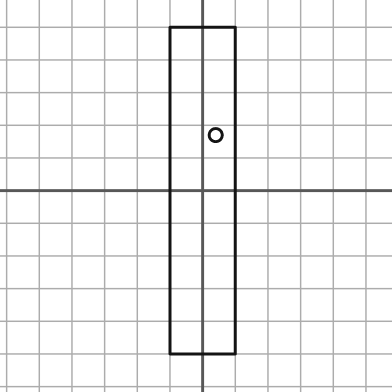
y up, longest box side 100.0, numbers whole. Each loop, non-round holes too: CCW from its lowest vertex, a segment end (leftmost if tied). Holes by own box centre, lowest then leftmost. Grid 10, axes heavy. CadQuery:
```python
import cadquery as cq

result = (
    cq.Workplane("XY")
    .moveTo(-10.0, -50.0)
    .lineTo(10.0, -50.0)
    .lineTo(10.0, 50.0)
    .lineTo(-10.0, 50.0)
    .close()
    .moveTo(4.0, 17.0)
    .circle(2.0)
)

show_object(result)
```